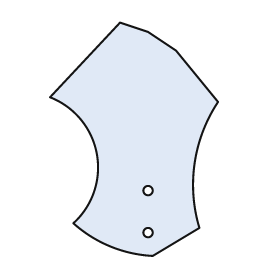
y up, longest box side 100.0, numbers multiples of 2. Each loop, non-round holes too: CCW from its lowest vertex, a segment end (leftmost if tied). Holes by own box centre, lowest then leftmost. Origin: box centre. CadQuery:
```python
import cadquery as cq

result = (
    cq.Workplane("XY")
    .moveTo(8.0, -50.0)
    .lineTo(28.0, -38.0)
    .threePointArc((26.0, -10.0), (36.0, 16.0))
    .lineTo(18.0, 38.0)
    .lineTo(6.0, 46.0)
    .lineTo(-6.0, 50.0)
    .lineTo(-36.0, 18.0)
    .threePointArc((-16.0, -6.0), (-26.0, -36.0))
    .threePointArc((-10.0, -46.0), (8.0, -50.0))
    .close()
    .moveTo(6.0, -40.0)
    .circle(2.0)
    .moveTo(6.0, -22.0)
    .circle(2.0)
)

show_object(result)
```